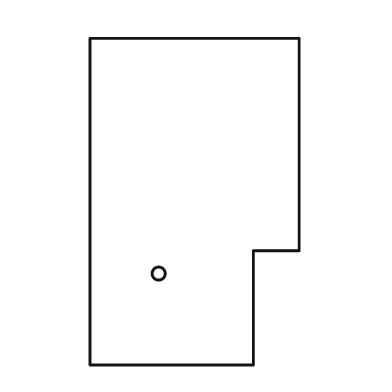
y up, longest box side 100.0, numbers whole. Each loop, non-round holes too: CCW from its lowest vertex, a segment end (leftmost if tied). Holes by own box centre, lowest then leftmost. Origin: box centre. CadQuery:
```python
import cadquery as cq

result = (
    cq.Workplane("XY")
    .moveTo(-32.0, -50.0)
    .lineTo(18.0, -50.0)
    .lineTo(18.0, -15.0)
    .lineTo(32.0, -15.0)
    .lineTo(32.0, 50.0)
    .lineTo(-32.0, 50.0)
    .close()
    .moveTo(-11.0, -22.0)
    .circle(2.0)
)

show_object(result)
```